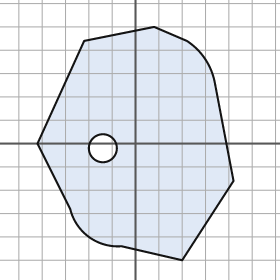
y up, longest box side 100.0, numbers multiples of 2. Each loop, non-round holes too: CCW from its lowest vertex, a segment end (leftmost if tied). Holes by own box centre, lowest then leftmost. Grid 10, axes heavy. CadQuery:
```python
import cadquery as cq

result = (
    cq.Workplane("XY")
    .moveTo(20.0, -50.0)
    .lineTo(42.0, -16.0)
    .lineTo(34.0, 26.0)
    .threePointArc((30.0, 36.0), (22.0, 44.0))
    .lineTo(8.0, 50.0)
    .lineTo(-22.0, 44.0)
    .lineTo(-42.0, 0.0)
    .lineTo(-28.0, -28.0)
    .threePointArc((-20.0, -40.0), (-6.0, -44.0))
    .close()
    .moveTo(-14.0, -2.0)
    .circle(6.0)
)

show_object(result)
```